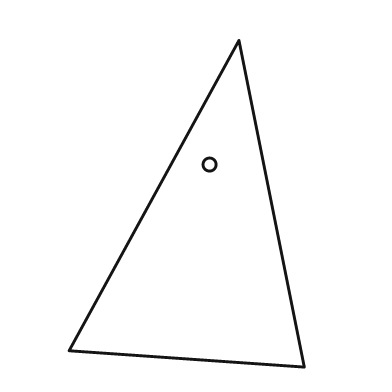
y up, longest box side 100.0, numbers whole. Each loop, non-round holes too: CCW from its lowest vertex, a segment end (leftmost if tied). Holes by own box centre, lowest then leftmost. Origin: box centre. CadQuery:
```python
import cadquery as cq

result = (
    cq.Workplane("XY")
    .moveTo(36.0, -50.0)
    .lineTo(16.0, 50.0)
    .lineTo(-36.0, -45.0)
    .close()
    .moveTo(7.0, 12.0)
    .circle(2.0)
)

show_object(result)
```